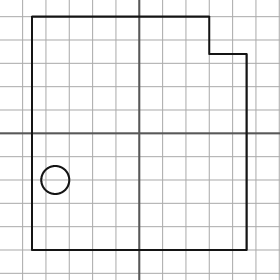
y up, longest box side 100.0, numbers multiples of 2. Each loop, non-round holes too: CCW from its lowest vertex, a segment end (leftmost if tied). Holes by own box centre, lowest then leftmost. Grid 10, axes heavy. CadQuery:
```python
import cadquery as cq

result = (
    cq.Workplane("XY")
    .moveTo(-46.0, -50.0)
    .lineTo(46.0, -50.0)
    .lineTo(46.0, 34.0)
    .lineTo(30.0, 34.0)
    .lineTo(30.0, 50.0)
    .lineTo(-46.0, 50.0)
    .close()
    .moveTo(-36.0, -20.0)
    .circle(6.0)
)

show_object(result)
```